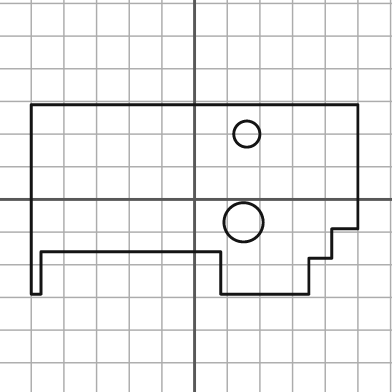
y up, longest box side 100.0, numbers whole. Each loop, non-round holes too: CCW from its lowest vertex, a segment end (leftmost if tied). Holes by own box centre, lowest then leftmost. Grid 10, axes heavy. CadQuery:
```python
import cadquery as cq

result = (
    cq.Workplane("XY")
    .moveTo(-50.0, -29.0)
    .lineTo(-47.0, -29.0)
    .lineTo(-47.0, -16.0)
    .lineTo(8.0, -16.0)
    .lineTo(8.0, -29.0)
    .lineTo(35.0, -29.0)
    .lineTo(35.0, -18.0)
    .lineTo(42.0, -18.0)
    .lineTo(42.0, -9.0)
    .lineTo(50.0, -9.0)
    .lineTo(50.0, 29.0)
    .lineTo(-50.0, 29.0)
    .close()
    .moveTo(15.0, -7.0)
    .circle(6.0)
    .moveTo(16.0, 20.0)
    .circle(4.0)
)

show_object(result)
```